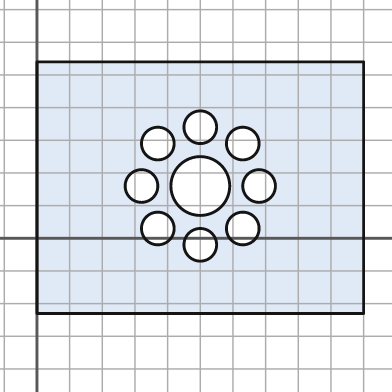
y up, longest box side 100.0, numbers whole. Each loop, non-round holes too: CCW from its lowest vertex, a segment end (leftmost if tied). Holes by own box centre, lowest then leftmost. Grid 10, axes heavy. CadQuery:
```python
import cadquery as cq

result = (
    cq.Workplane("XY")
    .moveTo(0.0, -23.0)
    .lineTo(100.0, -23.0)
    .lineTo(100.0, 54.0)
    .lineTo(0.0, 54.0)
    .close()
    .moveTo(50.0, -2.0)
    .circle(5.0)
    .moveTo(37.0, 3.0)
    .circle(5.0)
    .moveTo(63.0, 3.0)
    .circle(5.0)
    .moveTo(32.0, 16.0)
    .circle(5.0)
    .moveTo(50.0, 16.0)
    .circle(9.0)
    .moveTo(68.0, 16.0)
    .circle(5.0)
    .moveTo(37.0, 29.0)
    .circle(5.0)
    .moveTo(63.0, 29.0)
    .circle(5.0)
    .moveTo(50.0, 34.0)
    .circle(5.0)
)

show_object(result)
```